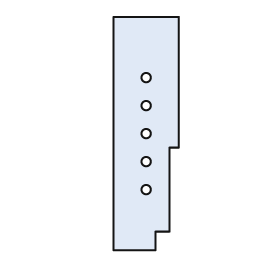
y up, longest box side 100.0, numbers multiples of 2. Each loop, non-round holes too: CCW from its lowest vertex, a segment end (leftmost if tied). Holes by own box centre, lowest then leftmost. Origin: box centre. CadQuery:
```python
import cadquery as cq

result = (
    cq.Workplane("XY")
    .moveTo(-14.0, -50.0)
    .lineTo(4.0, -50.0)
    .lineTo(4.0, -42.0)
    .lineTo(10.0, -42.0)
    .lineTo(10.0, -6.0)
    .lineTo(14.0, -6.0)
    .lineTo(14.0, 50.0)
    .lineTo(-14.0, 50.0)
    .close()
    .moveTo(0.0, -24.0)
    .circle(2.0)
    .moveTo(0.0, -12.0)
    .circle(2.0)
    .moveTo(0.0, 0.0)
    .circle(2.0)
    .moveTo(0.0, 12.0)
    .circle(2.0)
    .moveTo(0.0, 24.0)
    .circle(2.0)
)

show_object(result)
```